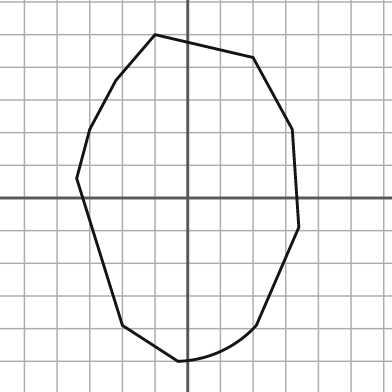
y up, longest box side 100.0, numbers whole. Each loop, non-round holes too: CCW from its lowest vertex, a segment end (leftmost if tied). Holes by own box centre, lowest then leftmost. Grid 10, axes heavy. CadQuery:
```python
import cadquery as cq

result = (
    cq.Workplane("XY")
    .moveTo(-3.0, -50.0)
    .threePointArc((10.0, -47.0), (21.0, -39.0))
    .lineTo(34.0, -9.0)
    .lineTo(32.0, 21.0)
    .lineTo(20.0, 43.0)
    .lineTo(-10.0, 50.0)
    .lineTo(-22.0, 36.0)
    .lineTo(-30.0, 21.0)
    .lineTo(-34.0, 6.0)
    .lineTo(-20.0, -39.0)
    .close()
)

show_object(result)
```